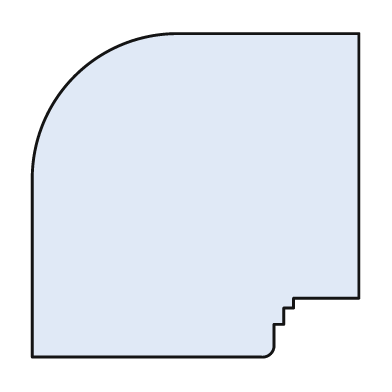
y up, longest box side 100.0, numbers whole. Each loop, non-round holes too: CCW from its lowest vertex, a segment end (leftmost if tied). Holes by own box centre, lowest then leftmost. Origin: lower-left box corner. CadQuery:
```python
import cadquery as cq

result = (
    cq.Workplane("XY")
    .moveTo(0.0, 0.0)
    .lineTo(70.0, 0.0)
    .threePointArc((73.0, 1.0), (74.0, 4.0))
    .lineTo(74.0, 10.0)
    .lineTo(77.0, 10.0)
    .lineTo(77.0, 15.0)
    .lineTo(80.0, 15.0)
    .lineTo(80.0, 18.0)
    .lineTo(100.0, 18.0)
    .lineTo(100.0, 99.0)
    .lineTo(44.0, 99.0)
    .threePointArc((13.0, 86.0), (0.0, 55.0))
    .close()
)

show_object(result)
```